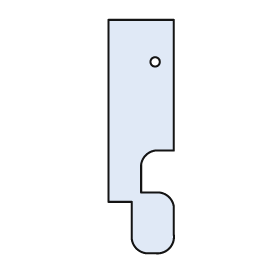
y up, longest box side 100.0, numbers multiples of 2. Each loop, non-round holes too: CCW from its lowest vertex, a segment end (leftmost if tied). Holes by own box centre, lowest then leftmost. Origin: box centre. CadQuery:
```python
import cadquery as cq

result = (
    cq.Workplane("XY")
    .moveTo(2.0, -50.0)
    .lineTo(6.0, -50.0)
    .threePointArc((12.0, -48.0), (14.0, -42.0))
    .lineTo(14.0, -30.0)
    .threePointArc((12.0, -26.0), (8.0, -24.0))
    .lineTo(0.0, -24.0)
    .lineTo(0.0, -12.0)
    .threePointArc((2.0, -8.0), (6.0, -6.0))
    .lineTo(14.0, -6.0)
    .lineTo(14.0, 50.0)
    .lineTo(-14.0, 50.0)
    .lineTo(-14.0, -28.0)
    .lineTo(-4.0, -28.0)
    .lineTo(-4.0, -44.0)
    .threePointArc((-2.0, -48.0), (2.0, -50.0))
    .close()
    .moveTo(6.0, 32.0)
    .circle(2.0)
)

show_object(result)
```